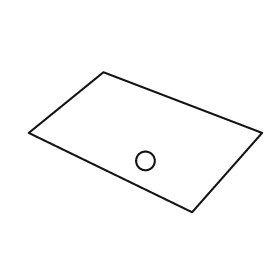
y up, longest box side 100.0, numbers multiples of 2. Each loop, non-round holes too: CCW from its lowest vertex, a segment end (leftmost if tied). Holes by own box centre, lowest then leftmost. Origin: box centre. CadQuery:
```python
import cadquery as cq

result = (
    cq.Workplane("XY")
    .moveTo(20.0, -30.0)
    .lineTo(50.0, 4.0)
    .lineTo(-18.0, 30.0)
    .lineTo(-50.0, 4.0)
    .close()
    .moveTo(0.0, -8.0)
    .circle(4.0)
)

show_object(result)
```